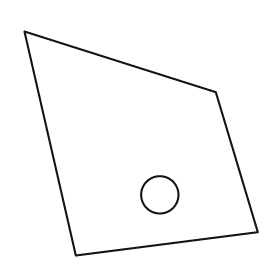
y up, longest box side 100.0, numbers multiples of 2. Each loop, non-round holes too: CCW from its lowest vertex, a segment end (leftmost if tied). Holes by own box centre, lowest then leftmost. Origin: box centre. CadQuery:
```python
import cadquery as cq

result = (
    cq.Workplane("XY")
    .moveTo(-28.0, -48.0)
    .lineTo(50.0, -38.0)
    .lineTo(32.0, 22.0)
    .lineTo(-50.0, 48.0)
    .close()
    .moveTo(8.0, -22.0)
    .circle(8.0)
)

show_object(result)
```